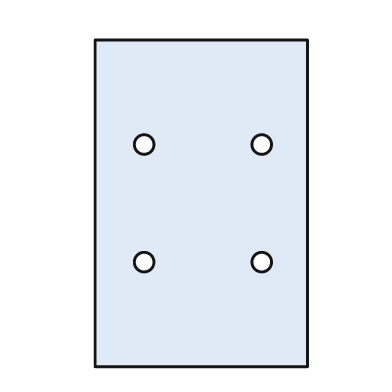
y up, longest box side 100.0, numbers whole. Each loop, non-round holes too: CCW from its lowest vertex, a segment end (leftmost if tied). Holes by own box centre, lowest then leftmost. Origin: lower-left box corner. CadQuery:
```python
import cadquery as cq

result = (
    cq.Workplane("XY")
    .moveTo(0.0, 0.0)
    .lineTo(65.0, 0.0)
    .lineTo(65.0, 100.0)
    .lineTo(0.0, 100.0)
    .close()
    .moveTo(15.0, 32.0)
    .circle(3.0)
    .moveTo(51.0, 32.0)
    .circle(3.0)
    .moveTo(15.0, 68.0)
    .circle(3.0)
    .moveTo(51.0, 68.0)
    .circle(3.0)
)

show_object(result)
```